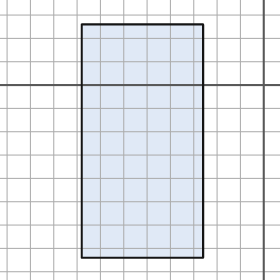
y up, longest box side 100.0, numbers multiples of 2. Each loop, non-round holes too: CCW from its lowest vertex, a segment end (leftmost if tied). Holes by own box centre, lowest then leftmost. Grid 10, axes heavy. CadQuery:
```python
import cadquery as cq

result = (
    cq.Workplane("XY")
    .moveTo(-78.0, -74.0)
    .lineTo(-26.0, -74.0)
    .lineTo(-26.0, 26.0)
    .lineTo(-78.0, 26.0)
    .close()
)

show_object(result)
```